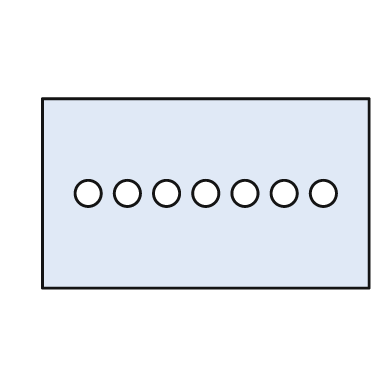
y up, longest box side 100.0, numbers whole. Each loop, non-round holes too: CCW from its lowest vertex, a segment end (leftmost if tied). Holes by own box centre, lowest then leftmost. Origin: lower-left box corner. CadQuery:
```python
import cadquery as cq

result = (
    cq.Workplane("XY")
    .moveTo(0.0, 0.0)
    .lineTo(100.0, 0.0)
    .lineTo(100.0, 58.0)
    .lineTo(0.0, 58.0)
    .close()
    .moveTo(14.0, 29.0)
    .circle(4.0)
    .moveTo(26.0, 29.0)
    .circle(4.0)
    .moveTo(38.0, 29.0)
    .circle(4.0)
    .moveTo(50.0, 29.0)
    .circle(4.0)
    .moveTo(62.0, 29.0)
    .circle(4.0)
    .moveTo(74.0, 29.0)
    .circle(4.0)
    .moveTo(86.0, 29.0)
    .circle(4.0)
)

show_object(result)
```